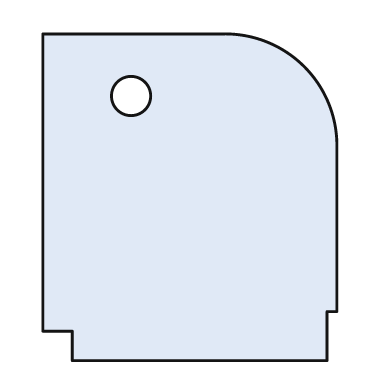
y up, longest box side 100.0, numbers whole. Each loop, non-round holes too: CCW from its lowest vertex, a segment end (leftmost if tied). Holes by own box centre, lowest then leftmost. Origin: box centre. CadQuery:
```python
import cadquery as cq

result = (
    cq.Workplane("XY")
    .moveTo(-36.0, -50.0)
    .lineTo(42.0, -50.0)
    .lineTo(42.0, -35.0)
    .lineTo(45.0, -35.0)
    .lineTo(45.0, 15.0)
    .threePointArc((35.0, 40.0), (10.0, 50.0))
    .lineTo(-45.0, 50.0)
    .lineTo(-45.0, -41.0)
    .lineTo(-36.0, -41.0)
    .close()
    .moveTo(-18.0, 31.0)
    .circle(6.0)
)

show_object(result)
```